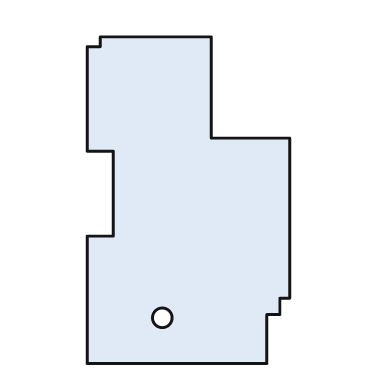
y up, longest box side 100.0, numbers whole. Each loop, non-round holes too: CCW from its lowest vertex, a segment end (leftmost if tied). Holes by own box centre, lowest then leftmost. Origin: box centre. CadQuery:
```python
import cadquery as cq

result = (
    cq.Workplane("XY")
    .moveTo(-31.0, -50.0)
    .lineTo(24.0, -50.0)
    .lineTo(24.0, -35.0)
    .lineTo(28.0, -35.0)
    .lineTo(28.0, -30.0)
    .lineTo(31.0, -30.0)
    .lineTo(31.0, 19.0)
    .lineTo(7.0, 19.0)
    .lineTo(7.0, 50.0)
    .lineTo(-27.0, 50.0)
    .lineTo(-27.0, 47.0)
    .lineTo(-31.0, 47.0)
    .lineTo(-31.0, 15.0)
    .lineTo(-23.0, 15.0)
    .lineTo(-23.0, -11.0)
    .lineTo(-31.0, -11.0)
    .close()
    .moveTo(-8.0, -36.0)
    .circle(3.0)
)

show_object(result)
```